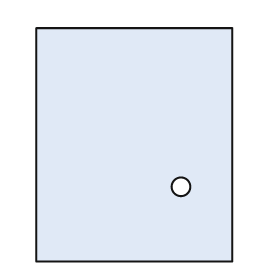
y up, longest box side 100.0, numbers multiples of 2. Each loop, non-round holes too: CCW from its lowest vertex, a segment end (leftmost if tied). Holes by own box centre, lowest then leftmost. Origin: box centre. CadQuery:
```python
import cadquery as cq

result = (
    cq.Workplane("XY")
    .moveTo(-42.0, -50.0)
    .lineTo(42.0, -50.0)
    .lineTo(42.0, 50.0)
    .lineTo(-42.0, 50.0)
    .close()
    .moveTo(20.0, -18.0)
    .circle(4.0)
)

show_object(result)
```